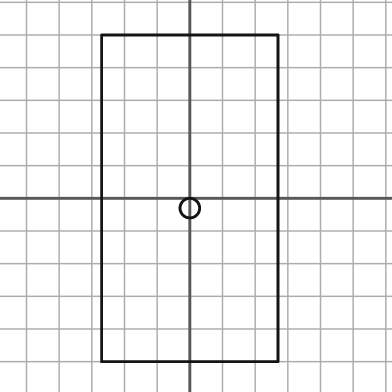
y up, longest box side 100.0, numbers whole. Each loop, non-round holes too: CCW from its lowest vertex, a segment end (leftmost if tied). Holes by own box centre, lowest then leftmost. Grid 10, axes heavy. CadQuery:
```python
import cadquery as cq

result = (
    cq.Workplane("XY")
    .moveTo(-27.0, -50.0)
    .lineTo(27.0, -50.0)
    .lineTo(27.0, 50.0)
    .lineTo(-27.0, 50.0)
    .close()
    .moveTo(0.0, -3.0)
    .circle(3.0)
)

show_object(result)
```